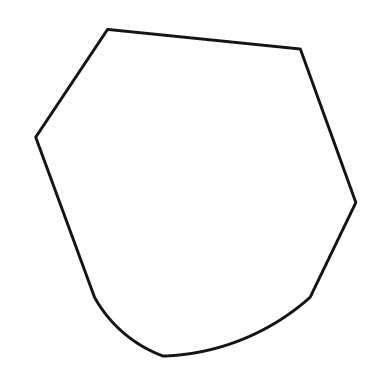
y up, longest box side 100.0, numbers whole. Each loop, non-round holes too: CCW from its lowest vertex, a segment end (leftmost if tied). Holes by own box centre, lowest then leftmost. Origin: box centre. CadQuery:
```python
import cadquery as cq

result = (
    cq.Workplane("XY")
    .moveTo(-10.0, -50.0)
    .threePointArc((14.0, -45.0), (35.0, -32.0))
    .lineTo(49.0, -3.0)
    .lineTo(32.0, 44.0)
    .lineTo(-27.0, 50.0)
    .lineTo(-49.0, 17.0)
    .lineTo(-31.0, -32.0)
    .threePointArc((-22.0, -43.0), (-10.0, -50.0))
    .close()
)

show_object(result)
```